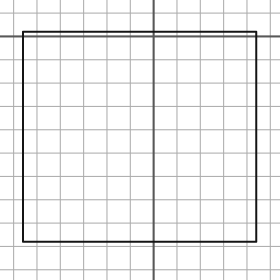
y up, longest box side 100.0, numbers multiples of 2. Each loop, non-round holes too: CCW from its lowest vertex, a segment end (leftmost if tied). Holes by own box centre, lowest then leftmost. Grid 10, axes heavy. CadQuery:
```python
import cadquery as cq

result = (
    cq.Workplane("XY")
    .moveTo(-56.0, -88.0)
    .lineTo(44.0, -88.0)
    .lineTo(44.0, 2.0)
    .lineTo(-56.0, 2.0)
    .close()
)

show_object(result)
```